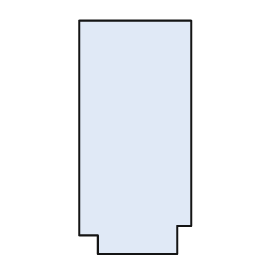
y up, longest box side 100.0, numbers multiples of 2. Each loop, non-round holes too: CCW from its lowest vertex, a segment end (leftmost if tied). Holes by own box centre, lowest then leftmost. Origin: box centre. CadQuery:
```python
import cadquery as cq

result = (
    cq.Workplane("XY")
    .moveTo(-16.0, -50.0)
    .lineTo(18.0, -50.0)
    .lineTo(18.0, -38.0)
    .lineTo(24.0, -38.0)
    .lineTo(24.0, 50.0)
    .lineTo(-24.0, 50.0)
    .lineTo(-24.0, -42.0)
    .lineTo(-16.0, -42.0)
    .close()
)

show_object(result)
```